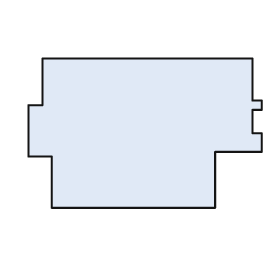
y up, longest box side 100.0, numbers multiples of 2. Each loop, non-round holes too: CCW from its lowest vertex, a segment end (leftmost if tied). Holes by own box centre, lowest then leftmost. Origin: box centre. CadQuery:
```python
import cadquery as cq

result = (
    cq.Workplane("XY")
    .moveTo(-40.0, -32.0)
    .lineTo(30.0, -32.0)
    .lineTo(30.0, -8.0)
    .lineTo(50.0, -8.0)
    .lineTo(50.0, 0.0)
    .lineTo(46.0, 0.0)
    .lineTo(46.0, 10.0)
    .lineTo(50.0, 10.0)
    .lineTo(50.0, 14.0)
    .lineTo(46.0, 14.0)
    .lineTo(46.0, 32.0)
    .lineTo(-44.0, 32.0)
    .lineTo(-44.0, 12.0)
    .lineTo(-50.0, 12.0)
    .lineTo(-50.0, -10.0)
    .lineTo(-40.0, -10.0)
    .close()
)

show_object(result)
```